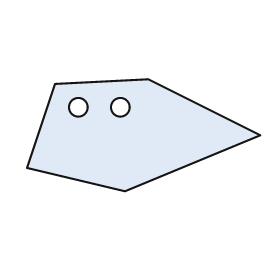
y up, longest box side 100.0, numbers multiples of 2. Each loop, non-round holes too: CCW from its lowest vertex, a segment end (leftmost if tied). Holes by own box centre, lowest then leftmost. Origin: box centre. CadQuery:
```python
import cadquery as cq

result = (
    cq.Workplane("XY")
    .moveTo(-8.0, -24.0)
    .lineTo(50.0, 0.0)
    .lineTo(2.0, 24.0)
    .lineTo(-38.0, 22.0)
    .lineTo(-50.0, -14.0)
    .close()
    .moveTo(-28.0, 12.0)
    .circle(4.0)
    .moveTo(-10.0, 12.0)
    .circle(4.0)
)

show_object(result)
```